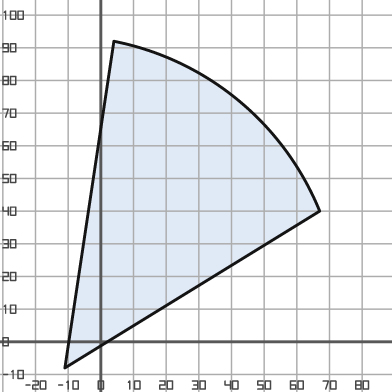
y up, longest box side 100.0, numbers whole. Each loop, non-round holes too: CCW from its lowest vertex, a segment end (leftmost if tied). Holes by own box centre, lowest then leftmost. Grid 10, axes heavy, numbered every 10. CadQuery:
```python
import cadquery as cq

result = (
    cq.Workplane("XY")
    .moveTo(-11.0, -8.0)
    .lineTo(67.0, 40.0)
    .threePointArc((42.0, 74.0), (4.0, 92.0))
    .close()
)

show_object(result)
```